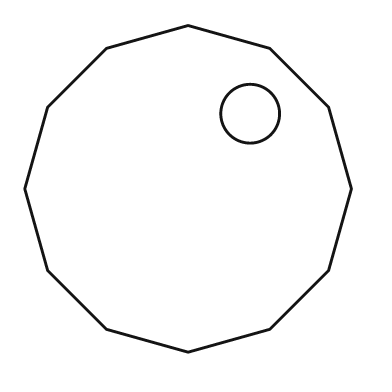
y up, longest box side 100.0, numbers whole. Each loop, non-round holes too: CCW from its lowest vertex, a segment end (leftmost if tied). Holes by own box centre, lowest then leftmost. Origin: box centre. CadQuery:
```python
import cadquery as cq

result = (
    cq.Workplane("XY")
    .moveTo(0.0, -50.0)
    .lineTo(25.0, -43.0)
    .lineTo(43.0, -25.0)
    .lineTo(50.0, 0.0)
    .lineTo(43.0, 25.0)
    .lineTo(25.0, 43.0)
    .lineTo(0.0, 50.0)
    .lineTo(-25.0, 43.0)
    .lineTo(-43.0, 25.0)
    .lineTo(-50.0, 0.0)
    .lineTo(-43.0, -25.0)
    .lineTo(-25.0, -43.0)
    .close()
    .moveTo(19.0, 23.0)
    .circle(9.0)
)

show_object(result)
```